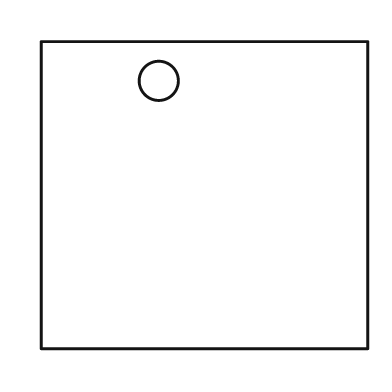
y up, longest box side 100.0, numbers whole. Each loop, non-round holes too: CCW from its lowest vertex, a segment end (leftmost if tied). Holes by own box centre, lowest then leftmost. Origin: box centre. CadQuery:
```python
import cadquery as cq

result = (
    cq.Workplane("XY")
    .moveTo(-50.0, -47.0)
    .lineTo(50.0, -47.0)
    .lineTo(50.0, 47.0)
    .lineTo(-50.0, 47.0)
    .close()
    .moveTo(-14.0, 35.0)
    .circle(6.0)
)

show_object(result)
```